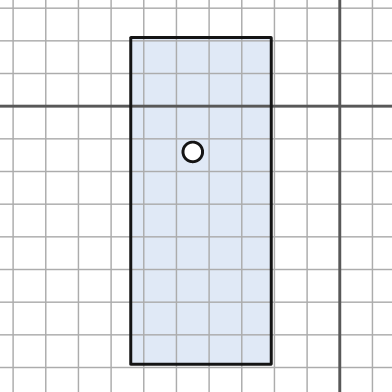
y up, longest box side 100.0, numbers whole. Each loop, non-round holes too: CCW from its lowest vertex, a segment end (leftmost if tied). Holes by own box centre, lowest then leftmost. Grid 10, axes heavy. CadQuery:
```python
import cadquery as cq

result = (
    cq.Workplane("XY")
    .moveTo(-64.0, -79.0)
    .lineTo(-21.0, -79.0)
    .lineTo(-21.0, 21.0)
    .lineTo(-64.0, 21.0)
    .close()
    .moveTo(-45.0, -14.0)
    .circle(3.0)
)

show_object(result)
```